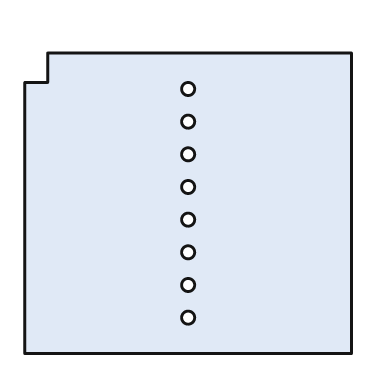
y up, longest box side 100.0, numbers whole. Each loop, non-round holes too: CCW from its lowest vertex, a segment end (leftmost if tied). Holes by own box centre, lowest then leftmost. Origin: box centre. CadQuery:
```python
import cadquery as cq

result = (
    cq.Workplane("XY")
    .moveTo(-50.0, -46.0)
    .lineTo(50.0, -46.0)
    .lineTo(50.0, 46.0)
    .lineTo(-43.0, 46.0)
    .lineTo(-43.0, 37.0)
    .lineTo(-50.0, 37.0)
    .close()
    .moveTo(0.0, -35.0)
    .circle(2.0)
    .moveTo(0.0, -25.0)
    .circle(2.0)
    .moveTo(0.0, -15.0)
    .circle(2.0)
    .moveTo(0.0, -5.0)
    .circle(2.0)
    .moveTo(0.0, 5.0)
    .circle(2.0)
    .moveTo(0.0, 15.0)
    .circle(2.0)
    .moveTo(0.0, 25.0)
    .circle(2.0)
    .moveTo(0.0, 35.0)
    .circle(2.0)
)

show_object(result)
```